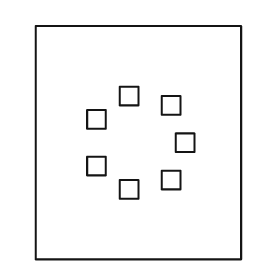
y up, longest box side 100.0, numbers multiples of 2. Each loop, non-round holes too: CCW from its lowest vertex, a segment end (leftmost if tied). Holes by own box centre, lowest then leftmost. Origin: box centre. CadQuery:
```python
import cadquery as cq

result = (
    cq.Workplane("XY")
    .moveTo(-44.0, -50.0)
    .lineTo(44.0, -50.0)
    .lineTo(44.0, 50.0)
    .lineTo(-44.0, 50.0)
    .close()
    .moveTo(-8.0, -24.0)
    .lineTo(0.0, -24.0)
    .lineTo(0.0, -16.0)
    .lineTo(-8.0, -16.0)
    .close()
    .moveTo(10.0, -20.0)
    .lineTo(18.0, -20.0)
    .lineTo(18.0, -12.0)
    .lineTo(10.0, -12.0)
    .close()
    .moveTo(-22.0, -14.0)
    .lineTo(-14.0, -14.0)
    .lineTo(-14.0, -6.0)
    .lineTo(-22.0, -6.0)
    .close()
    .moveTo(16.0, -4.0)
    .lineTo(24.0, -4.0)
    .lineTo(24.0, 4.0)
    .lineTo(16.0, 4.0)
    .close()
    .moveTo(-22.0, 6.0)
    .lineTo(-14.0, 6.0)
    .lineTo(-14.0, 14.0)
    .lineTo(-22.0, 14.0)
    .close()
    .moveTo(10.0, 12.0)
    .lineTo(18.0, 12.0)
    .lineTo(18.0, 20.0)
    .lineTo(10.0, 20.0)
    .close()
    .moveTo(-8.0, 16.0)
    .lineTo(0.0, 16.0)
    .lineTo(0.0, 24.0)
    .lineTo(-8.0, 24.0)
    .close()
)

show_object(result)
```